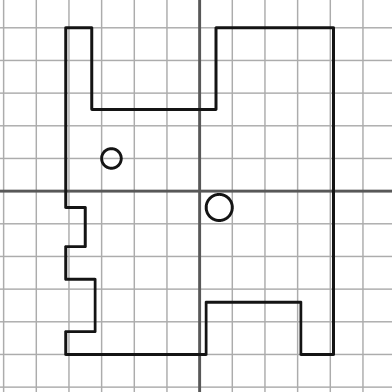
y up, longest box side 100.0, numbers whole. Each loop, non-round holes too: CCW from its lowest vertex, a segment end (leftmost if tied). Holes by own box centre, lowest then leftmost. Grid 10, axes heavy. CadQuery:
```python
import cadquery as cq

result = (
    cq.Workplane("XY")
    .moveTo(-41.0, -50.0)
    .lineTo(2.0, -50.0)
    .lineTo(2.0, -34.0)
    .lineTo(31.0, -34.0)
    .lineTo(31.0, -50.0)
    .lineTo(41.0, -50.0)
    .lineTo(41.0, 50.0)
    .lineTo(5.0, 50.0)
    .lineTo(5.0, 25.0)
    .lineTo(-33.0, 25.0)
    .lineTo(-33.0, 50.0)
    .lineTo(-41.0, 50.0)
    .lineTo(-41.0, -5.0)
    .lineTo(-35.0, -5.0)
    .lineTo(-35.0, -17.0)
    .lineTo(-41.0, -17.0)
    .lineTo(-41.0, -27.0)
    .lineTo(-32.0, -27.0)
    .lineTo(-32.0, -43.0)
    .lineTo(-41.0, -43.0)
    .close()
    .moveTo(6.0, -5.0)
    .circle(4.0)
    .moveTo(-27.0, 10.0)
    .circle(3.0)
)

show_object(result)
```